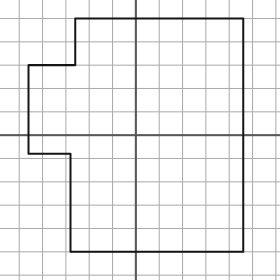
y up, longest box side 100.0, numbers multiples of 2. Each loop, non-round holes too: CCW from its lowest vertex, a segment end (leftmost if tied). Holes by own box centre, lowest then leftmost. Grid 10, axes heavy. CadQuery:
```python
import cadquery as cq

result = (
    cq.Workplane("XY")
    .moveTo(-28.0, -50.0)
    .lineTo(46.0, -50.0)
    .lineTo(46.0, 50.0)
    .lineTo(-26.0, 50.0)
    .lineTo(-26.0, 30.0)
    .lineTo(-46.0, 30.0)
    .lineTo(-46.0, -8.0)
    .lineTo(-28.0, -8.0)
    .close()
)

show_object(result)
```